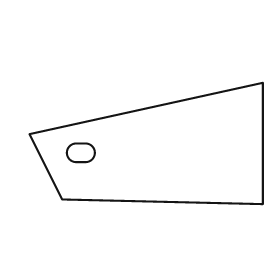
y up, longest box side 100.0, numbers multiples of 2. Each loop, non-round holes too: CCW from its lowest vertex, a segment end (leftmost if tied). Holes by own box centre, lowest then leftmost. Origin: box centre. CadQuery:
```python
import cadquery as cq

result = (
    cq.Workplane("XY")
    .moveTo(50.0, -26.0)
    .lineTo(50.0, 26.0)
    .lineTo(-50.0, 4.0)
    .lineTo(-36.0, -24.0)
    .close()
    .moveTo(-30.0, -8.0)
    .lineTo(-26.0, -8.0)
    .threePointArc((-22.0, -4.0), (-26.0, 0.0))
    .lineTo(-30.0, 0.0)
    .threePointArc((-34.0, -4.0), (-30.0, -8.0))
    .close()
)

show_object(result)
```